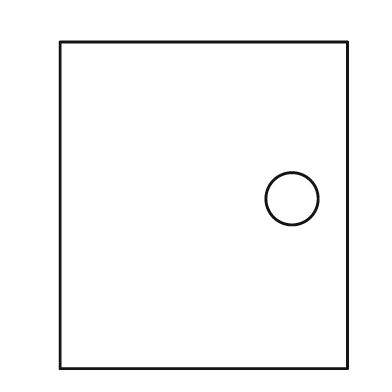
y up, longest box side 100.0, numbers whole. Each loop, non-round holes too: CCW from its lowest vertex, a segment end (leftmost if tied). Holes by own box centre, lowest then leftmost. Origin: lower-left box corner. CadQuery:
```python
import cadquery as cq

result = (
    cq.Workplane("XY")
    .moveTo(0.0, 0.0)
    .lineTo(88.0, 0.0)
    .lineTo(88.0, 100.0)
    .lineTo(0.0, 100.0)
    .close()
    .moveTo(71.0, 52.0)
    .circle(8.0)
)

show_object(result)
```